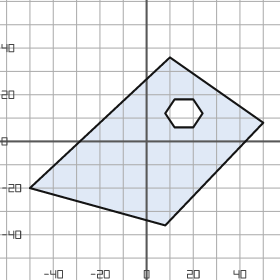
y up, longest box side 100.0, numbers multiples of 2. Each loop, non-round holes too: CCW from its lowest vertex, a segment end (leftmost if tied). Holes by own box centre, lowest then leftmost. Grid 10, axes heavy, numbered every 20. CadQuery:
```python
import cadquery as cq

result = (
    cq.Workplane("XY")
    .moveTo(8.0, -36.0)
    .lineTo(50.0, 8.0)
    .lineTo(10.0, 36.0)
    .lineTo(-50.0, -20.0)
    .close()
    .moveTo(12.0, 6.0)
    .lineTo(20.0, 6.0)
    .lineTo(24.0, 12.0)
    .lineTo(20.0, 18.0)
    .lineTo(12.0, 18.0)
    .lineTo(8.0, 12.0)
    .close()
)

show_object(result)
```